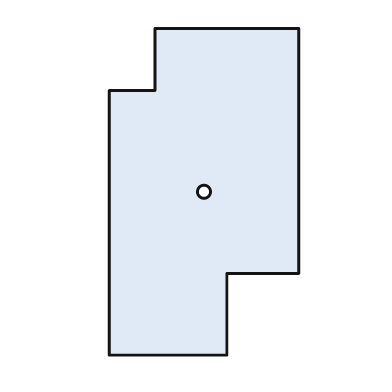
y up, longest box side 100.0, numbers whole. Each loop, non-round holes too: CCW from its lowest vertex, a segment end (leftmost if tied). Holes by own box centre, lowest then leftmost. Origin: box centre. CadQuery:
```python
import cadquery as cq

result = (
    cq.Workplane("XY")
    .moveTo(-29.0, -50.0)
    .lineTo(7.0, -50.0)
    .lineTo(7.0, -25.0)
    .lineTo(29.0, -25.0)
    .lineTo(29.0, 50.0)
    .lineTo(-15.0, 50.0)
    .lineTo(-15.0, 31.0)
    .lineTo(-29.0, 31.0)
    .close()
    .moveTo(0.0, 0.0)
    .circle(2.0)
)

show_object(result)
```